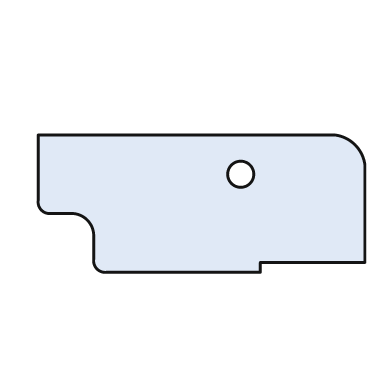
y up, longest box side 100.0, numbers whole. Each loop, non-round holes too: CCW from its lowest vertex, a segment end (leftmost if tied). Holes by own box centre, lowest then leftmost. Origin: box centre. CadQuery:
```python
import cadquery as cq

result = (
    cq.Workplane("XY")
    .moveTo(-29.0, -21.0)
    .lineTo(18.0, -21.0)
    .lineTo(18.0, -18.0)
    .lineTo(50.0, -18.0)
    .lineTo(50.0, 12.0)
    .threePointArc((47.0, 18.0), (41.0, 21.0))
    .lineTo(-50.0, 21.0)
    .lineTo(-50.0, 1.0)
    .threePointArc((-49.0, -2.0), (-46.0, -3.0))
    .lineTo(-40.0, -3.0)
    .threePointArc((-35.0, -5.0), (-33.0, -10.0))
    .lineTo(-33.0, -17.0)
    .threePointArc((-32.0, -20.0), (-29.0, -21.0))
    .close()
    .moveTo(12.0, 9.0)
    .circle(4.0)
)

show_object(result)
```